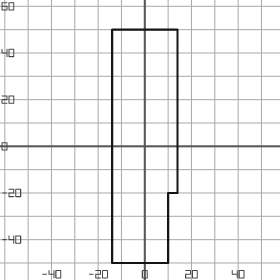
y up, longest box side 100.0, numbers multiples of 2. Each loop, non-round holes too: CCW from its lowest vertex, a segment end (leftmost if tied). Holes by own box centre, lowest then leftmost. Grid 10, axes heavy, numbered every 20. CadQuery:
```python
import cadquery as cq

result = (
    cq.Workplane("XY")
    .moveTo(-14.0, -50.0)
    .lineTo(10.0, -50.0)
    .lineTo(10.0, -20.0)
    .lineTo(14.0, -20.0)
    .lineTo(14.0, 50.0)
    .lineTo(-14.0, 50.0)
    .close()
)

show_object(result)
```